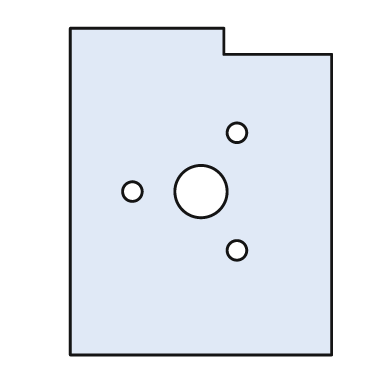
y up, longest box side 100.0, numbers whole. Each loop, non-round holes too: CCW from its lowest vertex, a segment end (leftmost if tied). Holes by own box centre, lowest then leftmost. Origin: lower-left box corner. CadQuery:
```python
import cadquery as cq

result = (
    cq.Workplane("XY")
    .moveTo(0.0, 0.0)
    .lineTo(80.0, 0.0)
    .lineTo(80.0, 92.0)
    .lineTo(47.0, 92.0)
    .lineTo(47.0, 100.0)
    .lineTo(0.0, 100.0)
    .close()
    .moveTo(51.0, 32.0)
    .circle(3.0)
    .moveTo(19.0, 50.0)
    .circle(3.0)
    .moveTo(40.0, 50.0)
    .circle(8.0)
    .moveTo(51.0, 68.0)
    .circle(3.0)
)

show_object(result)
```